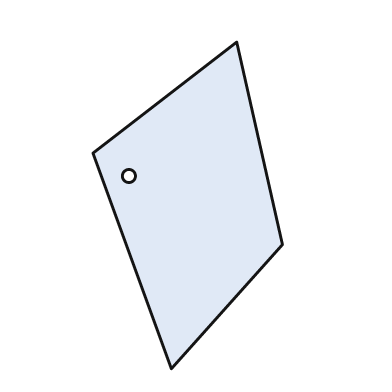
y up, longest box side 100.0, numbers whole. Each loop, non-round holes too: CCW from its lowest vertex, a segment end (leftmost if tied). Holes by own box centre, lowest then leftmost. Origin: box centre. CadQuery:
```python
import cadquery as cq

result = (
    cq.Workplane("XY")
    .moveTo(-5.0, -50.0)
    .lineTo(29.0, -12.0)
    .lineTo(15.0, 50.0)
    .lineTo(-29.0, 16.0)
    .close()
    .moveTo(-18.0, 9.0)
    .circle(2.0)
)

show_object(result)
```